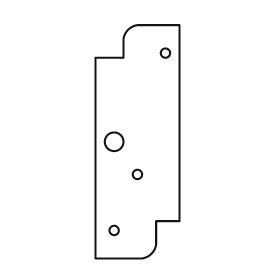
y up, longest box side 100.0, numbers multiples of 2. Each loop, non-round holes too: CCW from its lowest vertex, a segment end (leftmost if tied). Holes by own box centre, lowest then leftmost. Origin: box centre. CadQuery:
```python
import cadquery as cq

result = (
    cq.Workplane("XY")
    .moveTo(-18.0, -50.0)
    .lineTo(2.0, -50.0)
    .threePointArc((6.0, -48.0), (8.0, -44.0))
    .lineTo(8.0, -34.0)
    .lineTo(18.0, -34.0)
    .lineTo(18.0, 50.0)
    .lineTo(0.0, 50.0)
    .threePointArc((-4.0, 48.0), (-6.0, 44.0))
    .lineTo(-6.0, 36.0)
    .lineTo(-18.0, 36.0)
    .close()
    .moveTo(-10.0, -38.0)
    .circle(2.0)
    .moveTo(0.0, -14.0)
    .circle(2.0)
    .moveTo(-10.0, 0.0)
    .circle(4.0)
    .moveTo(12.0, 38.0)
    .circle(2.0)
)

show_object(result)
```